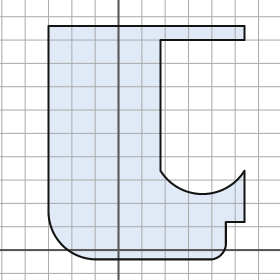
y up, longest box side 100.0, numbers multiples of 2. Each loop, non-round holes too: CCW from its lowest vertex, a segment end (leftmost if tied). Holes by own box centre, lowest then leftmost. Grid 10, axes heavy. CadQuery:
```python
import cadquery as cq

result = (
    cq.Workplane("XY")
    .moveTo(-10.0, -4.0)
    .lineTo(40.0, -4.0)
    .threePointArc((44.0, -2.0), (46.0, 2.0))
    .lineTo(46.0, 12.0)
    .lineTo(54.0, 12.0)
    .lineTo(54.0, 34.0)
    .threePointArc((36.0, 24.0), (18.0, 34.0))
    .lineTo(18.0, 90.0)
    .lineTo(54.0, 90.0)
    .lineTo(54.0, 96.0)
    .lineTo(-30.0, 96.0)
    .lineTo(-30.0, 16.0)
    .threePointArc((-24.0, 2.0), (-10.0, -4.0))
    .close()
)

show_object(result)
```